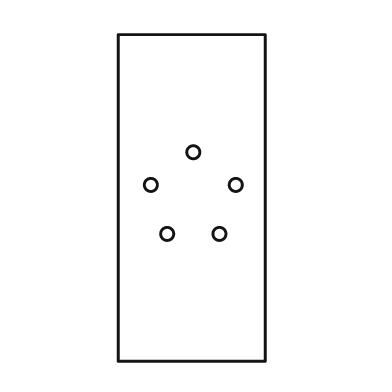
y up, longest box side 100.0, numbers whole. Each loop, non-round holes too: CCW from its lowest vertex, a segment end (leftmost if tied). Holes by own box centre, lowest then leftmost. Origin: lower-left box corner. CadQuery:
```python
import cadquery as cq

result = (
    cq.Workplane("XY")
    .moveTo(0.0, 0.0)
    .lineTo(45.0, 0.0)
    .lineTo(45.0, 100.0)
    .lineTo(0.0, 100.0)
    .close()
    .moveTo(15.0, 39.0)
    .circle(2.0)
    .moveTo(31.0, 39.0)
    .circle(2.0)
    .moveTo(10.0, 54.0)
    .circle(2.0)
    .moveTo(36.0, 54.0)
    .circle(2.0)
    .moveTo(23.0, 64.0)
    .circle(2.0)
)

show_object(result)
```